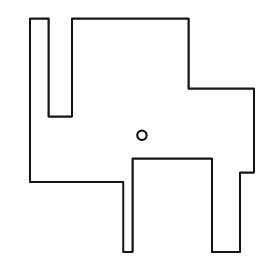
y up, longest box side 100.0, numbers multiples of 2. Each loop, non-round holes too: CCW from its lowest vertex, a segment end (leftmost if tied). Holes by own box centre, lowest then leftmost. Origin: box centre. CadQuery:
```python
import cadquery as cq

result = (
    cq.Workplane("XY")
    .moveTo(-8.0, -50.0)
    .lineTo(-4.0, -50.0)
    .lineTo(-4.0, -10.0)
    .lineTo(30.0, -10.0)
    .lineTo(30.0, -50.0)
    .lineTo(42.0, -50.0)
    .lineTo(42.0, -16.0)
    .lineTo(48.0, -16.0)
    .lineTo(48.0, 20.0)
    .lineTo(20.0, 20.0)
    .lineTo(20.0, 50.0)
    .lineTo(-30.0, 50.0)
    .lineTo(-30.0, 8.0)
    .lineTo(-40.0, 8.0)
    .lineTo(-40.0, 50.0)
    .lineTo(-48.0, 50.0)
    .lineTo(-48.0, -20.0)
    .lineTo(-8.0, -20.0)
    .close()
    .moveTo(0.0, 0.0)
    .circle(2.0)
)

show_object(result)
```